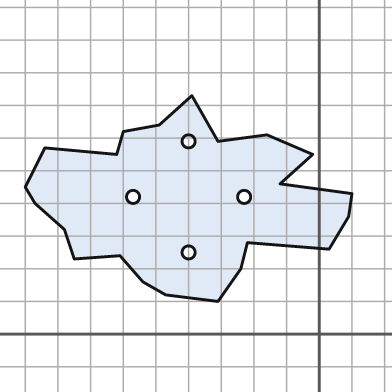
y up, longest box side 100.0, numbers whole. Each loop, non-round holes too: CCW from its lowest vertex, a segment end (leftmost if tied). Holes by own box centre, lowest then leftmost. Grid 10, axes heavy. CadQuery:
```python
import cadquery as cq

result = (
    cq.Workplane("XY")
    .moveTo(-31.0, 10.0)
    .lineTo(-24.0, 20.0)
    .lineTo(-22.0, 28.0)
    .lineTo(3.0, 26.0)
    .lineTo(9.0, 36.0)
    .lineTo(10.0, 43.0)
    .lineTo(-12.0, 46.0)
    .lineTo(-2.0, 55.0)
    .lineTo(-16.0, 61.0)
    .lineTo(-31.0, 59.0)
    .lineTo(-39.0, 73.0)
    .lineTo(-49.0, 64.0)
    .lineTo(-60.0, 62.0)
    .lineTo(-62.0, 55.0)
    .lineTo(-84.0, 57.0)
    .lineTo(-90.0, 45.0)
    .lineTo(-87.0, 40.0)
    .lineTo(-78.0, 32.0)
    .lineTo(-75.0, 23.0)
    .lineTo(-61.0, 24.0)
    .lineTo(-54.0, 16.0)
    .lineTo(-47.0, 12.0)
    .close()
    .moveTo(-40.0, 25.0)
    .circle(2.0)
    .moveTo(-57.0, 42.0)
    .circle(2.0)
    .moveTo(-23.0, 42.0)
    .circle(2.0)
    .moveTo(-40.0, 59.0)
    .circle(2.0)
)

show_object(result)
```